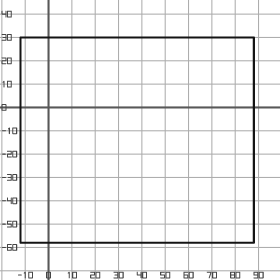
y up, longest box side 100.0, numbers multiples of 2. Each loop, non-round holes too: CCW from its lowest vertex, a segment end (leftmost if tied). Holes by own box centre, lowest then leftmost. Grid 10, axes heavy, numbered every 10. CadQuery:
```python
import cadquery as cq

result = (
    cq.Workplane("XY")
    .moveTo(-12.0, -58.0)
    .lineTo(88.0, -58.0)
    .lineTo(88.0, 30.0)
    .lineTo(-12.0, 30.0)
    .close()
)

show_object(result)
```